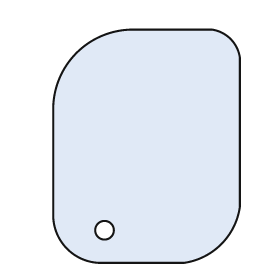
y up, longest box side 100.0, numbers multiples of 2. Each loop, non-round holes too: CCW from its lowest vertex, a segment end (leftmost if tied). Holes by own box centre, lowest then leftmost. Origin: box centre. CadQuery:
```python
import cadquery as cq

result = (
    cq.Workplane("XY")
    .moveTo(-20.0, -50.0)
    .lineTo(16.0, -50.0)
    .threePointArc((32.0, -42.0), (40.0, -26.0))
    .lineTo(40.0, 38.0)
    .threePointArc((36.0, 46.0), (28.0, 50.0))
    .lineTo(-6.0, 50.0)
    .threePointArc((-30.0, 40.0), (-40.0, 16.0))
    .lineTo(-40.0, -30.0)
    .threePointArc((-34.0, -44.0), (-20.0, -50.0))
    .close()
    .moveTo(-18.0, -36.0)
    .circle(4.0)
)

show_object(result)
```